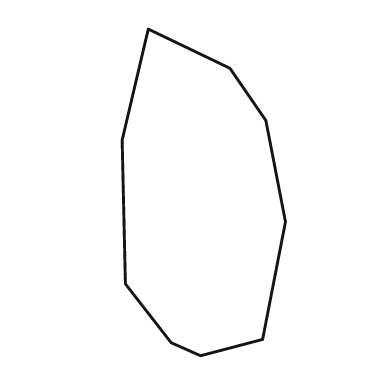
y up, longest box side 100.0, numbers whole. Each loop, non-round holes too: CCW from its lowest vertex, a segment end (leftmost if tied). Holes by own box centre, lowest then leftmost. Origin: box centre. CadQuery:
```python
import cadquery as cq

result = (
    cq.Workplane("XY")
    .moveTo(-1.0, -50.0)
    .lineTo(18.0, -45.0)
    .lineTo(25.0, -9.0)
    .lineTo(19.0, 22.0)
    .lineTo(8.0, 38.0)
    .lineTo(-17.0, 50.0)
    .lineTo(-25.0, 16.0)
    .lineTo(-24.0, -28.0)
    .lineTo(-10.0, -46.0)
    .close()
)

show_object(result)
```